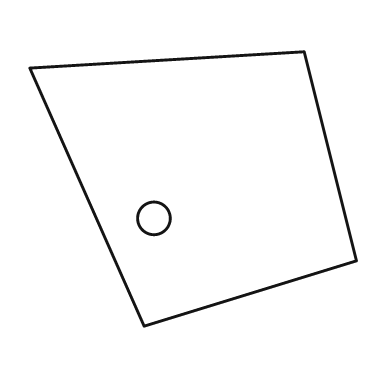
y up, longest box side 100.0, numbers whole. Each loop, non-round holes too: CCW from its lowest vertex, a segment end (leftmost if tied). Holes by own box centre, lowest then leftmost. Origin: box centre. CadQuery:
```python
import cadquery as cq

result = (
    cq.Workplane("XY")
    .moveTo(-15.0, -42.0)
    .lineTo(50.0, -22.0)
    .lineTo(34.0, 42.0)
    .lineTo(-50.0, 37.0)
    .close()
    .moveTo(-12.0, -9.0)
    .circle(5.0)
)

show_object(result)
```